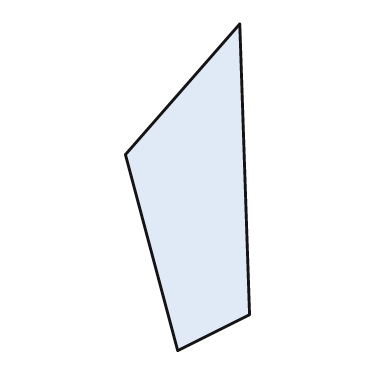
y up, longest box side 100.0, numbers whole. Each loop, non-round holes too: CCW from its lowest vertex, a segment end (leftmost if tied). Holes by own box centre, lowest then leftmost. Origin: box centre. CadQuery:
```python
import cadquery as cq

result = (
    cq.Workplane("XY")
    .moveTo(-3.0, -50.0)
    .lineTo(19.0, -39.0)
    .lineTo(16.0, 50.0)
    .lineTo(-19.0, 10.0)
    .close()
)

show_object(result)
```